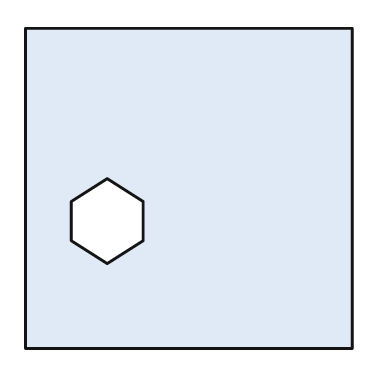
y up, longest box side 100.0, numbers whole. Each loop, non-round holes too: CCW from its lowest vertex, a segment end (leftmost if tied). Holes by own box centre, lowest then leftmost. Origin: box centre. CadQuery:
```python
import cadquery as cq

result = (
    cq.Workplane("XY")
    .moveTo(-50.0, -49.0)
    .lineTo(50.0, -49.0)
    .lineTo(50.0, 49.0)
    .lineTo(-50.0, 49.0)
    .close()
    .moveTo(-25.0, -23.0)
    .lineTo(-14.0, -16.0)
    .lineTo(-14.0, -4.0)
    .lineTo(-25.0, 3.0)
    .lineTo(-36.0, -4.0)
    .lineTo(-36.0, -16.0)
    .close()
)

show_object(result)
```